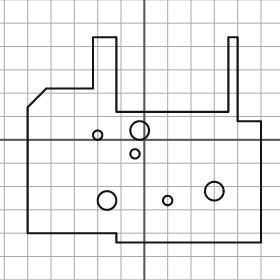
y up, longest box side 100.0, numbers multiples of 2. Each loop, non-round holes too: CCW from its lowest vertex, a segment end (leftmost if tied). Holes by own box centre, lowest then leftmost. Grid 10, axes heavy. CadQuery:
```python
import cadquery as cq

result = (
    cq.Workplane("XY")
    .moveTo(-12.0, -44.0)
    .lineTo(50.0, -44.0)
    .lineTo(50.0, 8.0)
    .lineTo(40.0, 8.0)
    .lineTo(40.0, 44.0)
    .lineTo(36.0, 44.0)
    .lineTo(36.0, 12.0)
    .lineTo(-12.0, 12.0)
    .lineTo(-12.0, 44.0)
    .lineTo(-22.0, 44.0)
    .lineTo(-22.0, 22.0)
    .lineTo(-42.0, 22.0)
    .lineTo(-50.0, 14.0)
    .lineTo(-50.0, -40.0)
    .lineTo(-12.0, -40.0)
    .close()
    .moveTo(-16.0, -26.0)
    .circle(4.0)
    .moveTo(10.0, -26.0)
    .circle(2.0)
    .moveTo(30.0, -22.0)
    .circle(4.0)
    .moveTo(-4.0, -6.0)
    .circle(2.0)
    .moveTo(-20.0, 2.0)
    .circle(2.0)
    .moveTo(-2.0, 4.0)
    .circle(4.0)
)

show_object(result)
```